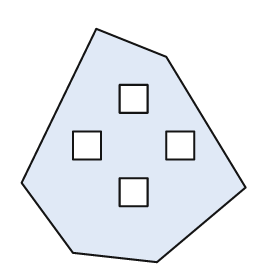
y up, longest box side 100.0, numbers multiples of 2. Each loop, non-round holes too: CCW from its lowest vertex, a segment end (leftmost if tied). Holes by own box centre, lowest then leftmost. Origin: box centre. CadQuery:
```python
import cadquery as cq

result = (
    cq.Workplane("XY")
    .moveTo(10.0, -50.0)
    .lineTo(48.0, -18.0)
    .lineTo(14.0, 38.0)
    .lineTo(-16.0, 50.0)
    .lineTo(-48.0, -16.0)
    .lineTo(-26.0, -46.0)
    .close()
    .moveTo(-6.0, -26.0)
    .lineTo(6.0, -26.0)
    .lineTo(6.0, -14.0)
    .lineTo(-6.0, -14.0)
    .close()
    .moveTo(-26.0, -6.0)
    .lineTo(-14.0, -6.0)
    .lineTo(-14.0, 6.0)
    .lineTo(-26.0, 6.0)
    .close()
    .moveTo(14.0, -6.0)
    .lineTo(26.0, -6.0)
    .lineTo(26.0, 6.0)
    .lineTo(14.0, 6.0)
    .close()
    .moveTo(-6.0, 14.0)
    .lineTo(6.0, 14.0)
    .lineTo(6.0, 26.0)
    .lineTo(-6.0, 26.0)
    .close()
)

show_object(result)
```